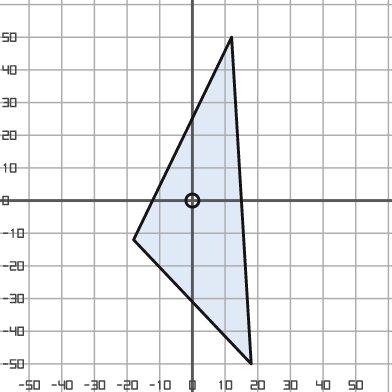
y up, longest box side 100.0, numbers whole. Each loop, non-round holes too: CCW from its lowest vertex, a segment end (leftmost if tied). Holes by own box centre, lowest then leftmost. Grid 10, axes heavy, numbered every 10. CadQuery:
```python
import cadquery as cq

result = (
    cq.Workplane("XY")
    .moveTo(18.0, -50.0)
    .lineTo(12.0, 50.0)
    .lineTo(-18.0, -12.0)
    .close()
    .moveTo(0.0, 0.0)
    .circle(2.0)
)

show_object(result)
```